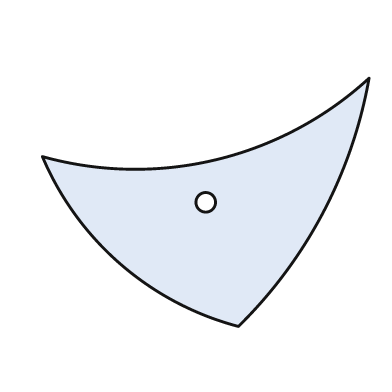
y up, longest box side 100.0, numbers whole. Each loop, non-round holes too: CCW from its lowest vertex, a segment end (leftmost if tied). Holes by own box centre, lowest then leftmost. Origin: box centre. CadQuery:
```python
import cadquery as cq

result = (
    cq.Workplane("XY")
    .moveTo(10.0, -38.0)
    .threePointArc((36.0, -3.0), (50.0, 38.0))
    .threePointArc((3.0, 13.0), (-50.0, 14.0))
    .threePointArc((-26.0, -19.0), (10.0, -38.0))
    .close()
    .moveTo(0.0, 0.0)
    .circle(3.0)
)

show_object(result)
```